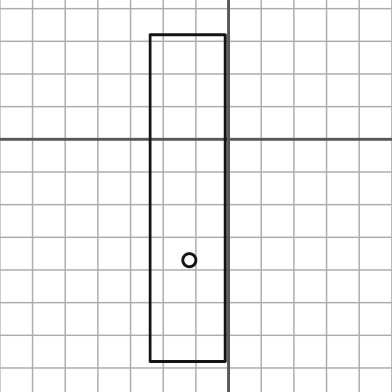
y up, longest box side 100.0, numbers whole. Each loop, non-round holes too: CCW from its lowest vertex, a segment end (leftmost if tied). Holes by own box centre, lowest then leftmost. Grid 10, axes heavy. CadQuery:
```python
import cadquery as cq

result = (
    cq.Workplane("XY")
    .moveTo(-24.0, -68.0)
    .lineTo(-1.0, -68.0)
    .lineTo(-1.0, 32.0)
    .lineTo(-24.0, 32.0)
    .close()
    .moveTo(-12.0, -37.0)
    .circle(2.0)
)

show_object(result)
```